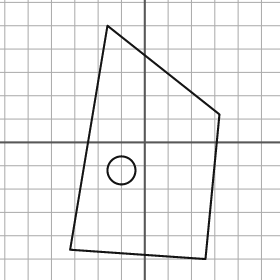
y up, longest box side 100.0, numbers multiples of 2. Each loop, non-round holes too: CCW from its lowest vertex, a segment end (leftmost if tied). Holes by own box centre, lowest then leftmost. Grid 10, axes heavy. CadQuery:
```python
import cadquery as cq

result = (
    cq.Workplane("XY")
    .moveTo(26.0, -50.0)
    .lineTo(32.0, 12.0)
    .lineTo(-16.0, 50.0)
    .lineTo(-32.0, -46.0)
    .close()
    .moveTo(-10.0, -12.0)
    .circle(6.0)
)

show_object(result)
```